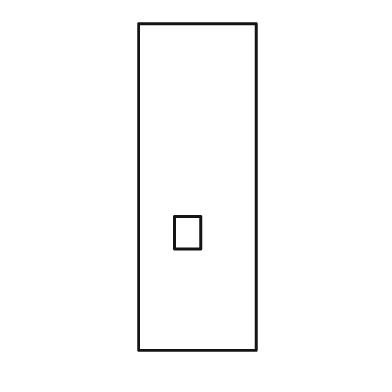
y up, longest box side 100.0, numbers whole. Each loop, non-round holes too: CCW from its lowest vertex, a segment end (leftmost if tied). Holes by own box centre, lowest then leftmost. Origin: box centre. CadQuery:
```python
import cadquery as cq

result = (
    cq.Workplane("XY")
    .moveTo(-18.0, -50.0)
    .lineTo(18.0, -50.0)
    .lineTo(18.0, 50.0)
    .lineTo(-18.0, 50.0)
    .close()
    .moveTo(-7.0, -19.0)
    .lineTo(1.0, -19.0)
    .lineTo(1.0, -9.0)
    .lineTo(-7.0, -9.0)
    .close()
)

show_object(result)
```